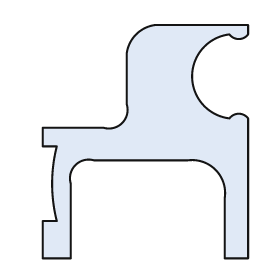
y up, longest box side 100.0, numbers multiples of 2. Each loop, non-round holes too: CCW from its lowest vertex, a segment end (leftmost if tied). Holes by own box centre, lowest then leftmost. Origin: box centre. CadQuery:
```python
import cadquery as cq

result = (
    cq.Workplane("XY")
    .moveTo(-44.0, -50.0)
    .lineTo(-32.0, -50.0)
    .lineTo(-32.0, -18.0)
    .threePointArc((-30.0, -10.0), (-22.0, -8.0))
    .lineTo(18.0, -8.0)
    .threePointArc((30.0, -12.0), (34.0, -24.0))
    .lineTo(34.0, -50.0)
    .lineTo(44.0, -50.0)
    .lineTo(44.0, 10.0)
    .threePointArc((40.0, 12.0), (36.0, 10.0))
    .threePointArc((20.0, 28.0), (36.0, 46.0))
    .threePointArc((40.0, 44.0), (44.0, 46.0))
    .lineTo(44.0, 50.0)
    .lineTo(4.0, 50.0)
    .threePointArc((-4.0, 46.0), (-8.0, 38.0))
    .lineTo(-8.0, 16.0)
    .threePointArc((-10.0, 8.0), (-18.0, 6.0))
    .lineTo(-44.0, 6.0)
    .lineTo(-44.0, -2.0)
    .lineTo(-38.0, -2.0)
    .threePointArc((-40.0, -18.0), (-38.0, -34.0))
    .lineTo(-44.0, -34.0)
    .close()
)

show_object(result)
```